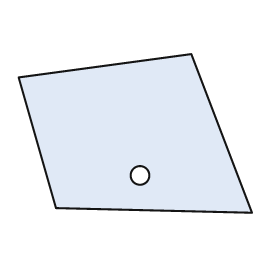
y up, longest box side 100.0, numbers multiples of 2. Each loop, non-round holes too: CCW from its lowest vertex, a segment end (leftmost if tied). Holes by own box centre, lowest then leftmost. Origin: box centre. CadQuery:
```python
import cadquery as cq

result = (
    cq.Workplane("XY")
    .moveTo(50.0, -34.0)
    .lineTo(24.0, 34.0)
    .lineTo(-50.0, 24.0)
    .lineTo(-34.0, -32.0)
    .close()
    .moveTo(2.0, -18.0)
    .circle(4.0)
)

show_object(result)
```